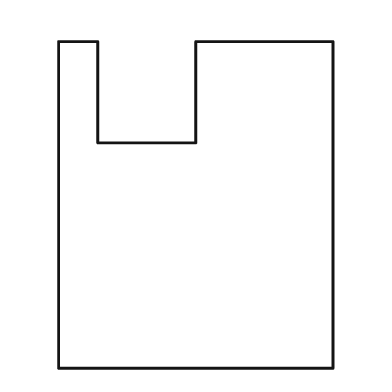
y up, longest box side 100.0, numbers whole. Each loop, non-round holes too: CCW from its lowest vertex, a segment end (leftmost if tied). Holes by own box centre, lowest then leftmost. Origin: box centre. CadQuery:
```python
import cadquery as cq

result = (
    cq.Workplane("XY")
    .moveTo(-42.0, -50.0)
    .lineTo(42.0, -50.0)
    .lineTo(42.0, 50.0)
    .lineTo(0.0, 50.0)
    .lineTo(0.0, 19.0)
    .lineTo(-30.0, 19.0)
    .lineTo(-30.0, 50.0)
    .lineTo(-42.0, 50.0)
    .close()
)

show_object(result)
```